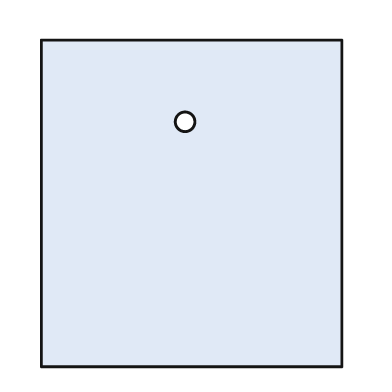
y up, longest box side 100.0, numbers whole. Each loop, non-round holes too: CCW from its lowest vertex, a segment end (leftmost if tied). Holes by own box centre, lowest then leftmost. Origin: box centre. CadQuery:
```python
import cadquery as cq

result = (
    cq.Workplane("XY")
    .moveTo(-46.0, -50.0)
    .lineTo(46.0, -50.0)
    .lineTo(46.0, 50.0)
    .lineTo(-46.0, 50.0)
    .close()
    .moveTo(-2.0, 25.0)
    .circle(3.0)
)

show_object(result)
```